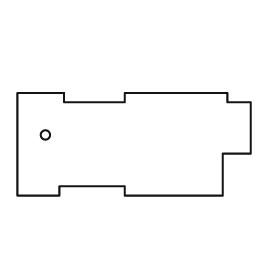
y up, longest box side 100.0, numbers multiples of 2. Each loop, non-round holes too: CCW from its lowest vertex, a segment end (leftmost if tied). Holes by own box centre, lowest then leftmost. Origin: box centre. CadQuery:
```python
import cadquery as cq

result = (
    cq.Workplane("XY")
    .moveTo(-50.0, -22.0)
    .lineTo(-32.0, -22.0)
    .lineTo(-32.0, -18.0)
    .lineTo(-4.0, -18.0)
    .lineTo(-4.0, -22.0)
    .lineTo(38.0, -22.0)
    .lineTo(38.0, -4.0)
    .lineTo(50.0, -4.0)
    .lineTo(50.0, 18.0)
    .lineTo(40.0, 18.0)
    .lineTo(40.0, 22.0)
    .lineTo(-4.0, 22.0)
    .lineTo(-4.0, 18.0)
    .lineTo(-30.0, 18.0)
    .lineTo(-30.0, 22.0)
    .lineTo(-50.0, 22.0)
    .close()
    .moveTo(-38.0, 4.0)
    .circle(2.0)
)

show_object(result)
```